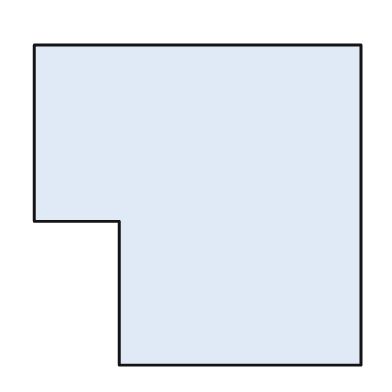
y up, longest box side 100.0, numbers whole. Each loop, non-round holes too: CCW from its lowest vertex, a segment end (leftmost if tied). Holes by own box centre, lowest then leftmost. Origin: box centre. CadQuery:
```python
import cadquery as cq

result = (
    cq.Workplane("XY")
    .moveTo(-24.0, -49.0)
    .lineTo(50.0, -49.0)
    .lineTo(50.0, 49.0)
    .lineTo(-50.0, 49.0)
    .lineTo(-50.0, -5.0)
    .lineTo(-24.0, -5.0)
    .close()
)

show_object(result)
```